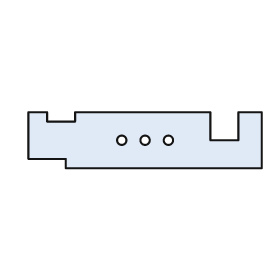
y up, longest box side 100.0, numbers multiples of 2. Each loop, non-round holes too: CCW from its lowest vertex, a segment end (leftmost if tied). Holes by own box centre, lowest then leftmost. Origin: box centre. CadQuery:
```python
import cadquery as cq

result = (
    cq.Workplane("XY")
    .moveTo(-34.0, -12.0)
    .lineTo(50.0, -12.0)
    .lineTo(50.0, 12.0)
    .lineTo(40.0, 12.0)
    .lineTo(40.0, 0.0)
    .lineTo(28.0, 0.0)
    .lineTo(28.0, 12.0)
    .lineTo(-30.0, 12.0)
    .lineTo(-30.0, 8.0)
    .lineTo(-42.0, 8.0)
    .lineTo(-42.0, 12.0)
    .lineTo(-50.0, 12.0)
    .lineTo(-50.0, -8.0)
    .lineTo(-34.0, -8.0)
    .close()
    .moveTo(-10.0, 0.0)
    .circle(2.0)
    .moveTo(0.0, 0.0)
    .circle(2.0)
    .moveTo(10.0, 0.0)
    .circle(2.0)
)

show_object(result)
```